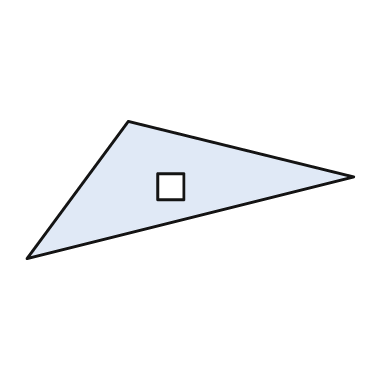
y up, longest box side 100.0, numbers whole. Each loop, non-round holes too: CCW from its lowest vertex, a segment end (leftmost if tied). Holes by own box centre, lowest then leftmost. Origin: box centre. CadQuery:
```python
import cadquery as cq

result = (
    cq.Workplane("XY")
    .moveTo(-50.0, -21.0)
    .lineTo(50.0, 4.0)
    .lineTo(-19.0, 21.0)
    .close()
    .moveTo(-10.0, -3.0)
    .lineTo(-2.0, -3.0)
    .lineTo(-2.0, 5.0)
    .lineTo(-10.0, 5.0)
    .close()
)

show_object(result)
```